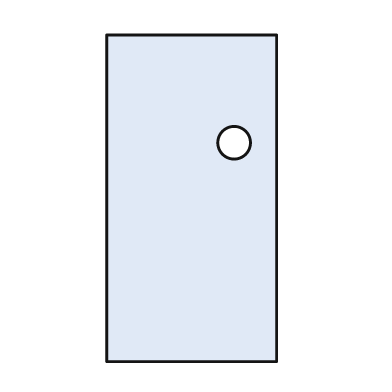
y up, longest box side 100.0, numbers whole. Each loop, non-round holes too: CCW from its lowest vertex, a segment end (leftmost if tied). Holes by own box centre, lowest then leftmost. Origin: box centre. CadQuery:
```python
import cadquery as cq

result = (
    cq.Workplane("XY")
    .moveTo(-26.0, -50.0)
    .lineTo(26.0, -50.0)
    .lineTo(26.0, 50.0)
    .lineTo(-26.0, 50.0)
    .close()
    .moveTo(13.0, 17.0)
    .circle(5.0)
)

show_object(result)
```